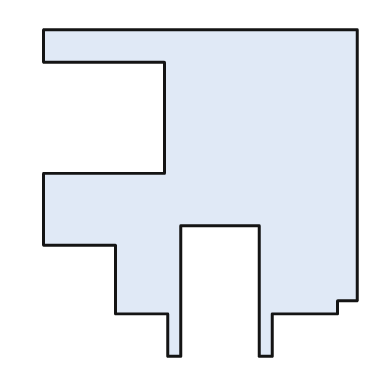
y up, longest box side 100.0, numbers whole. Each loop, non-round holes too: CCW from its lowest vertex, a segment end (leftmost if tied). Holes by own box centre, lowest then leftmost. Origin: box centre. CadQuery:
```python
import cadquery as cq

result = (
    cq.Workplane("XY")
    .moveTo(-10.0, -50.0)
    .lineTo(-6.0, -50.0)
    .lineTo(-6.0, -10.0)
    .lineTo(18.0, -10.0)
    .lineTo(18.0, -50.0)
    .lineTo(22.0, -50.0)
    .lineTo(22.0, -37.0)
    .lineTo(42.0, -37.0)
    .lineTo(42.0, -33.0)
    .lineTo(48.0, -33.0)
    .lineTo(48.0, 50.0)
    .lineTo(-48.0, 50.0)
    .lineTo(-48.0, 40.0)
    .lineTo(-11.0, 40.0)
    .lineTo(-11.0, 6.0)
    .lineTo(-48.0, 6.0)
    .lineTo(-48.0, -16.0)
    .lineTo(-26.0, -16.0)
    .lineTo(-26.0, -37.0)
    .lineTo(-10.0, -37.0)
    .close()
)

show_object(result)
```